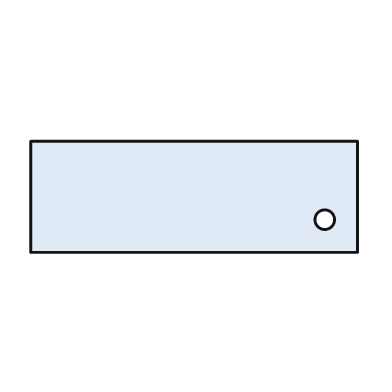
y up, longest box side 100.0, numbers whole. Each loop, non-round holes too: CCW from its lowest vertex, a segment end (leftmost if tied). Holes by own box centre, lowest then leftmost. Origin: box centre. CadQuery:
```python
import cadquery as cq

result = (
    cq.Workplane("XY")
    .moveTo(-50.0, -17.0)
    .lineTo(50.0, -17.0)
    .lineTo(50.0, 17.0)
    .lineTo(-50.0, 17.0)
    .close()
    .moveTo(40.0, -7.0)
    .circle(3.0)
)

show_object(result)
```